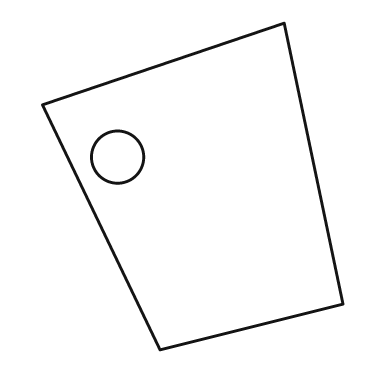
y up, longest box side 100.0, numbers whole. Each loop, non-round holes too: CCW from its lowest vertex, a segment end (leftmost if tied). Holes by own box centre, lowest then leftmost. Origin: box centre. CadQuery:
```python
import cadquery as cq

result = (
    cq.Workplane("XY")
    .moveTo(-10.0, -50.0)
    .lineTo(46.0, -36.0)
    .lineTo(28.0, 50.0)
    .lineTo(-46.0, 25.0)
    .close()
    .moveTo(-23.0, 9.0)
    .circle(8.0)
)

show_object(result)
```